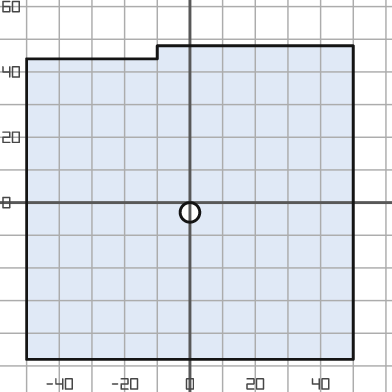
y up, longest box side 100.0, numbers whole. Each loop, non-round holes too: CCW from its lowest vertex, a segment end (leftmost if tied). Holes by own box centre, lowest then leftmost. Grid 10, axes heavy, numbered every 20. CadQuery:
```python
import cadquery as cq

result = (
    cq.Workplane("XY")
    .moveTo(-50.0, -48.0)
    .lineTo(50.0, -48.0)
    .lineTo(50.0, 48.0)
    .lineTo(-10.0, 48.0)
    .lineTo(-10.0, 44.0)
    .lineTo(-50.0, 44.0)
    .close()
    .moveTo(0.0, -3.0)
    .circle(3.0)
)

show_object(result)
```